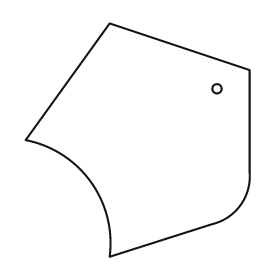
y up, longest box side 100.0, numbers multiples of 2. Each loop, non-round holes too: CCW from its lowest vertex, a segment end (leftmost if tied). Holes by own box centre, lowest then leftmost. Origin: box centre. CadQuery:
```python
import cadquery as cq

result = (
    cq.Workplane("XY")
    .moveTo(-12.0, -50.0)
    .lineTo(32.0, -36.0)
    .threePointArc((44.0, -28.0), (48.0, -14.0))
    .lineTo(48.0, 30.0)
    .lineTo(-12.0, 50.0)
    .lineTo(-48.0, 0.0)
    .threePointArc((-20.0, -18.0), (-12.0, -50.0))
    .close()
    .moveTo(34.0, 22.0)
    .circle(2.0)
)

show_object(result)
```